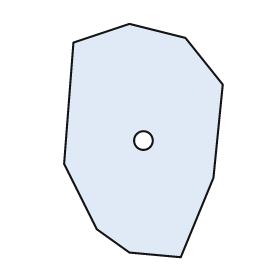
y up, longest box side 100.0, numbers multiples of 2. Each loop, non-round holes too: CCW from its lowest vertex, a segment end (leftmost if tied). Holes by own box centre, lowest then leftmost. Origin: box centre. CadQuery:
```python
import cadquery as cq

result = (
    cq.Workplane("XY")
    .moveTo(16.0, -50.0)
    .lineTo(30.0, -16.0)
    .lineTo(34.0, 24.0)
    .lineTo(18.0, 44.0)
    .lineTo(-6.0, 50.0)
    .lineTo(-30.0, 42.0)
    .lineTo(-34.0, -10.0)
    .lineTo(-20.0, -38.0)
    .lineTo(-6.0, -48.0)
    .close()
    .moveTo(0.0, 0.0)
    .circle(4.0)
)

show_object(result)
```